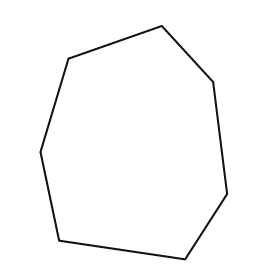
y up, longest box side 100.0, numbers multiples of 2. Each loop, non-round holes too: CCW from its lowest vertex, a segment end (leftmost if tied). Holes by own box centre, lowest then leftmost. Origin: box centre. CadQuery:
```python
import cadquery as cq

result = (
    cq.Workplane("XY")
    .moveTo(22.0, -50.0)
    .lineTo(40.0, -22.0)
    .lineTo(34.0, 26.0)
    .lineTo(12.0, 50.0)
    .lineTo(-28.0, 36.0)
    .lineTo(-40.0, -4.0)
    .lineTo(-32.0, -42.0)
    .close()
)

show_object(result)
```